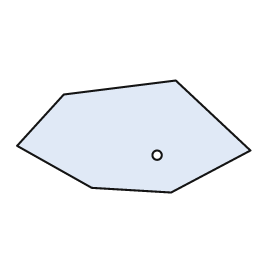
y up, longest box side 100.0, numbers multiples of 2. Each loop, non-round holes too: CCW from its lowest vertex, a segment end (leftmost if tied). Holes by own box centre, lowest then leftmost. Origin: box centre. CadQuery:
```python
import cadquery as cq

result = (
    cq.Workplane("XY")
    .moveTo(16.0, -24.0)
    .lineTo(50.0, -6.0)
    .lineTo(18.0, 24.0)
    .lineTo(-30.0, 18.0)
    .lineTo(-50.0, -4.0)
    .lineTo(-18.0, -22.0)
    .close()
    .moveTo(10.0, -8.0)
    .circle(2.0)
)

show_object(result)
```